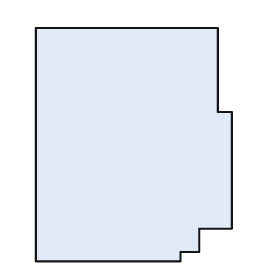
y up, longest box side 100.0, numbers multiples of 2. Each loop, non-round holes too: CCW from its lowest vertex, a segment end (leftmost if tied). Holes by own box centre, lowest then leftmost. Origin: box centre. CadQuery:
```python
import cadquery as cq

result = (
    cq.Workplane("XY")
    .moveTo(-42.0, -50.0)
    .lineTo(20.0, -50.0)
    .lineTo(20.0, -46.0)
    .lineTo(28.0, -46.0)
    .lineTo(28.0, -36.0)
    .lineTo(42.0, -36.0)
    .lineTo(42.0, 14.0)
    .lineTo(36.0, 14.0)
    .lineTo(36.0, 50.0)
    .lineTo(-42.0, 50.0)
    .close()
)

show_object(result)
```